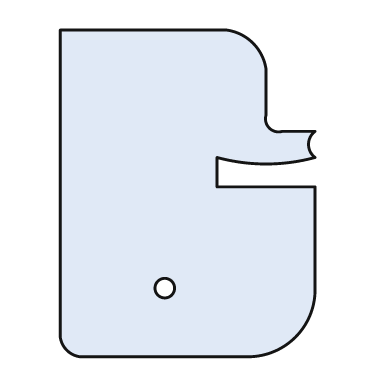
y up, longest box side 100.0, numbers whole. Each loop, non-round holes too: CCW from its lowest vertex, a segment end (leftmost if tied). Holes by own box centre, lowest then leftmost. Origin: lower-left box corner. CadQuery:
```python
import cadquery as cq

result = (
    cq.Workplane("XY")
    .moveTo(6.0, 0.0)
    .lineTo(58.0, 0.0)
    .threePointArc((72.0, 6.0), (78.0, 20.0))
    .lineTo(78.0, 52.0)
    .lineTo(48.0, 52.0)
    .lineTo(48.0, 61.0)
    .threePointArc((63.0, 59.0), (78.0, 61.0))
    .threePointArc((76.0, 65.0), (78.0, 69.0))
    .lineTo(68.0, 69.0)
    .threePointArc((64.0, 70.0), (63.0, 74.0))
    .lineTo(63.0, 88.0)
    .threePointArc((59.0, 96.0), (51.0, 100.0))
    .lineTo(0.0, 100.0)
    .lineTo(0.0, 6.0)
    .threePointArc((2.0, 2.0), (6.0, 0.0))
    .close()
    .moveTo(32.0, 21.0)
    .circle(3.0)
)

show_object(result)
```